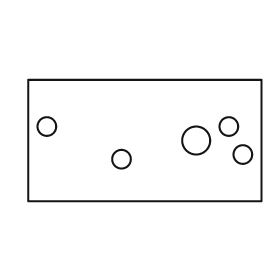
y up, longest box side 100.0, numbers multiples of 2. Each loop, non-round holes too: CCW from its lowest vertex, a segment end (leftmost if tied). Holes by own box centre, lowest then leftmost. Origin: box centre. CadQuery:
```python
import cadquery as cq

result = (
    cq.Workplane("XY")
    .moveTo(-50.0, -26.0)
    .lineTo(50.0, -26.0)
    .lineTo(50.0, 26.0)
    .lineTo(-50.0, 26.0)
    .close()
    .moveTo(-10.0, -8.0)
    .circle(4.0)
    .moveTo(42.0, -6.0)
    .circle(4.0)
    .moveTo(22.0, 0.0)
    .circle(6.0)
    .moveTo(-42.0, 6.0)
    .circle(4.0)
    .moveTo(36.0, 6.0)
    .circle(4.0)
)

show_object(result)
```